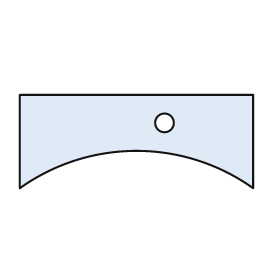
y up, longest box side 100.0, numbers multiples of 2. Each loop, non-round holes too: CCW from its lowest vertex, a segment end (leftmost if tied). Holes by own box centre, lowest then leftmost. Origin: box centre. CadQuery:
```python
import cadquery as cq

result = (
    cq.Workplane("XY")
    .moveTo(-50.0, -20.0)
    .threePointArc((0.0, -4.0), (50.0, -20.0))
    .lineTo(50.0, 20.0)
    .lineTo(-50.0, 20.0)
    .close()
    .moveTo(12.0, 8.0)
    .circle(4.0)
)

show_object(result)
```